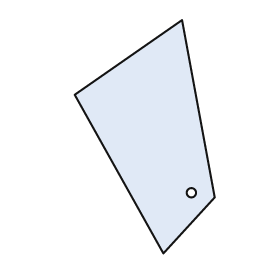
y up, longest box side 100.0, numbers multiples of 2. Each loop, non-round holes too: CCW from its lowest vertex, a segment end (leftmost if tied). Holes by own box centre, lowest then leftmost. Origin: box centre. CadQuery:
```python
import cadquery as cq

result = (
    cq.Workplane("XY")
    .moveTo(8.0, -50.0)
    .lineTo(30.0, -26.0)
    .lineTo(16.0, 50.0)
    .lineTo(-30.0, 18.0)
    .close()
    .moveTo(20.0, -24.0)
    .circle(2.0)
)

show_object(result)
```